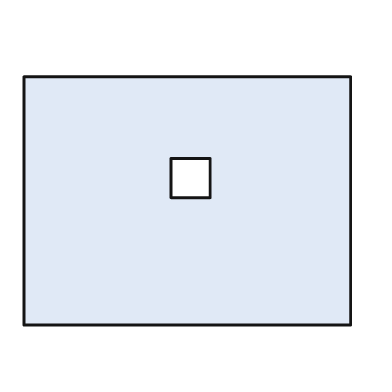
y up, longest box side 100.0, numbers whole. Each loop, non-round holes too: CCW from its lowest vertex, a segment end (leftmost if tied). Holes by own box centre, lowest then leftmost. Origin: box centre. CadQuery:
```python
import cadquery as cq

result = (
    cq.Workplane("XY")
    .moveTo(-50.0, -38.0)
    .lineTo(50.0, -38.0)
    .lineTo(50.0, 38.0)
    .lineTo(-50.0, 38.0)
    .close()
    .moveTo(-5.0, 1.0)
    .lineTo(7.0, 1.0)
    .lineTo(7.0, 13.0)
    .lineTo(-5.0, 13.0)
    .close()
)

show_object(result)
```